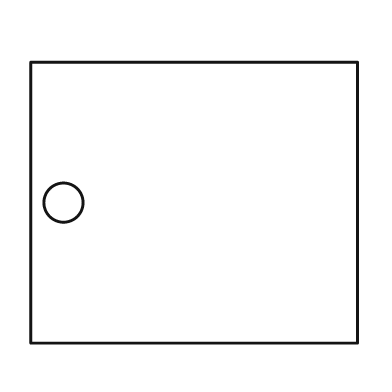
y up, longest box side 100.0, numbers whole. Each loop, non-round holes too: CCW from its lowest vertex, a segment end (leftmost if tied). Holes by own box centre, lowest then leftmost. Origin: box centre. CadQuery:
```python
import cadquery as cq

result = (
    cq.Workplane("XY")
    .moveTo(-50.0, -43.0)
    .lineTo(50.0, -43.0)
    .lineTo(50.0, 43.0)
    .lineTo(-50.0, 43.0)
    .close()
    .moveTo(-40.0, 0.0)
    .circle(6.0)
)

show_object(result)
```